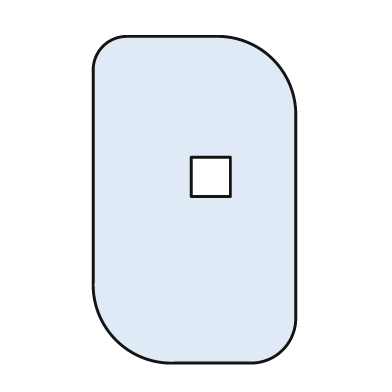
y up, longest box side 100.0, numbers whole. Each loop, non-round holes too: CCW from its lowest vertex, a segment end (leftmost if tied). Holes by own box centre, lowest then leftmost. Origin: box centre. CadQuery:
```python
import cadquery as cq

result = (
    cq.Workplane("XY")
    .moveTo(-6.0, -50.0)
    .lineTo(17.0, -50.0)
    .threePointArc((27.0, -46.0), (31.0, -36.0))
    .lineTo(31.0, 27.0)
    .threePointArc((24.0, 43.0), (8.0, 50.0))
    .lineTo(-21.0, 50.0)
    .threePointArc((-28.0, 47.0), (-31.0, 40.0))
    .lineTo(-31.0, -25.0)
    .threePointArc((-24.0, -43.0), (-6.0, -50.0))
    .close()
    .moveTo(-1.0, 1.0)
    .lineTo(11.0, 1.0)
    .lineTo(11.0, 13.0)
    .lineTo(-1.0, 13.0)
    .close()
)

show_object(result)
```